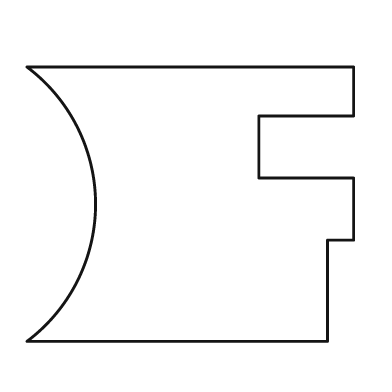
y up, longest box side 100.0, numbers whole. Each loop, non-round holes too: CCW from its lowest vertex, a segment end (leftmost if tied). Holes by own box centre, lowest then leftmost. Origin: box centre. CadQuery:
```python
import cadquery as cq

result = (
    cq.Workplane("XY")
    .moveTo(-50.0, -42.0)
    .lineTo(42.0, -42.0)
    .lineTo(42.0, -11.0)
    .lineTo(50.0, -11.0)
    .lineTo(50.0, 8.0)
    .lineTo(21.0, 8.0)
    .lineTo(21.0, 27.0)
    .lineTo(50.0, 27.0)
    .lineTo(50.0, 42.0)
    .lineTo(-50.0, 42.0)
    .threePointArc((-29.0, 0.0), (-50.0, -42.0))
    .close()
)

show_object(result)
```